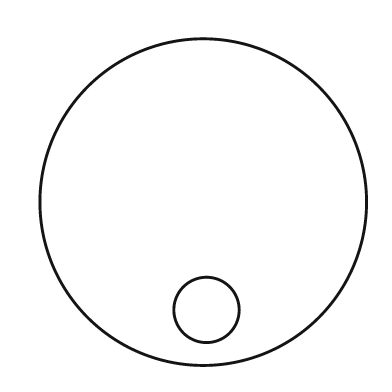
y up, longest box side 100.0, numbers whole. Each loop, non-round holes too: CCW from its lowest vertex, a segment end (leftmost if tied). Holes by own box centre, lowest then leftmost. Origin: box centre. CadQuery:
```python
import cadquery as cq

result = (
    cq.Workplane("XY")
    .moveTo(0.0, 0.0)
    .circle(50.0)
    .moveTo(1.0, -33.0)
    .circle(10.0)
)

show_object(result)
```